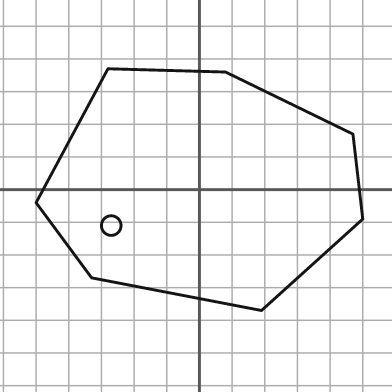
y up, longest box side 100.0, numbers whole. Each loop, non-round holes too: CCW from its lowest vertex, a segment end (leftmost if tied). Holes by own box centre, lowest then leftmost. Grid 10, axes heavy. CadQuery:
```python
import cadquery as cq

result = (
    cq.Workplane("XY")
    .moveTo(19.0, -37.0)
    .lineTo(50.0, -9.0)
    .lineTo(47.0, 17.0)
    .lineTo(8.0, 36.0)
    .lineTo(-28.0, 37.0)
    .lineTo(-50.0, -4.0)
    .lineTo(-33.0, -27.0)
    .close()
    .moveTo(-27.0, -11.0)
    .circle(3.0)
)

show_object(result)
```